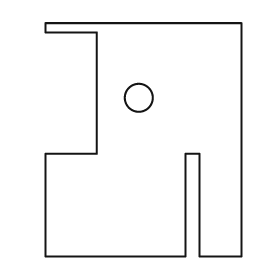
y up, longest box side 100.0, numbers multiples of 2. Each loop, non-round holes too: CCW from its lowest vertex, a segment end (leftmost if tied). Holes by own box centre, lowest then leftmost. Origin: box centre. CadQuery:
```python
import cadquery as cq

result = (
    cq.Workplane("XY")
    .moveTo(-42.0, -50.0)
    .lineTo(18.0, -50.0)
    .lineTo(18.0, -6.0)
    .lineTo(24.0, -6.0)
    .lineTo(24.0, -50.0)
    .lineTo(42.0, -50.0)
    .lineTo(42.0, 50.0)
    .lineTo(-42.0, 50.0)
    .lineTo(-42.0, 46.0)
    .lineTo(-20.0, 46.0)
    .lineTo(-20.0, -6.0)
    .lineTo(-42.0, -6.0)
    .close()
    .moveTo(-2.0, 18.0)
    .circle(6.0)
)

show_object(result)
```